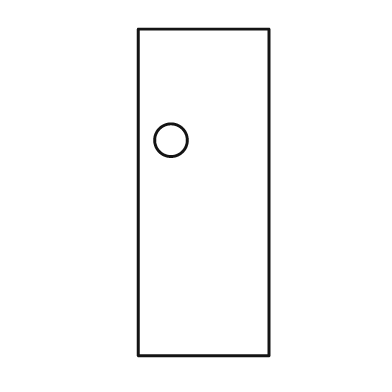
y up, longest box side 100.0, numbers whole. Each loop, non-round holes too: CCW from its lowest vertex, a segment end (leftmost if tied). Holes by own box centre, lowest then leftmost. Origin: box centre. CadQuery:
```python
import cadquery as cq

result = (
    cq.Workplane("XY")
    .moveTo(-20.0, -50.0)
    .lineTo(20.0, -50.0)
    .lineTo(20.0, 50.0)
    .lineTo(-20.0, 50.0)
    .close()
    .moveTo(-10.0, 16.0)
    .circle(5.0)
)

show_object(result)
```